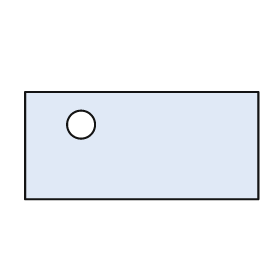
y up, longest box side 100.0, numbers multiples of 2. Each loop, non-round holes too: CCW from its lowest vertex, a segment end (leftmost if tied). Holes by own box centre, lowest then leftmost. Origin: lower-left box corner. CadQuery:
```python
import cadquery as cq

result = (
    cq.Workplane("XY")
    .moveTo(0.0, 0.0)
    .lineTo(100.0, 0.0)
    .lineTo(100.0, 46.0)
    .lineTo(0.0, 46.0)
    .close()
    .moveTo(24.0, 32.0)
    .circle(6.0)
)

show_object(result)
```